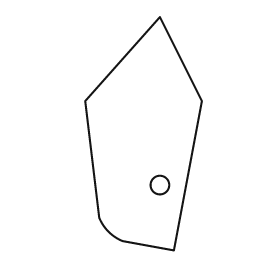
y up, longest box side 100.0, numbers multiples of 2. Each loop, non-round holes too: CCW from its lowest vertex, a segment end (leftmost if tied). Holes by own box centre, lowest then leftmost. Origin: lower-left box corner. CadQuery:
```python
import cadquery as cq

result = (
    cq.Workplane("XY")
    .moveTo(38.0, 0.0)
    .lineTo(50.0, 64.0)
    .lineTo(32.0, 100.0)
    .lineTo(0.0, 64.0)
    .lineTo(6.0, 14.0)
    .threePointArc((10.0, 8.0), (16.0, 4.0))
    .close()
    .moveTo(32.0, 28.0)
    .circle(4.0)
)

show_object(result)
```